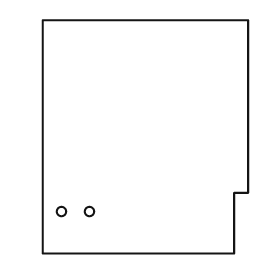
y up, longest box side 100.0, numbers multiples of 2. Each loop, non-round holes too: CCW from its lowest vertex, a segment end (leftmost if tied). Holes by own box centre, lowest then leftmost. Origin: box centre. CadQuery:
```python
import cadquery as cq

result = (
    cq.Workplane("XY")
    .moveTo(-44.0, -50.0)
    .lineTo(38.0, -50.0)
    .lineTo(38.0, -24.0)
    .lineTo(44.0, -24.0)
    .lineTo(44.0, 50.0)
    .lineTo(-44.0, 50.0)
    .close()
    .moveTo(-36.0, -32.0)
    .circle(2.0)
    .moveTo(-24.0, -32.0)
    .circle(2.0)
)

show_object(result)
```